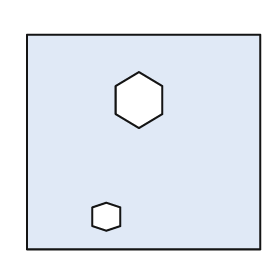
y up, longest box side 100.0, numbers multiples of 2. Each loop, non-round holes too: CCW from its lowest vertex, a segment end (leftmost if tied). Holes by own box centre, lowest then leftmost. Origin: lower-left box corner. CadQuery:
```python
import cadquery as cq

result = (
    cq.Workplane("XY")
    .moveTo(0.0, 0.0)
    .lineTo(100.0, 0.0)
    .lineTo(100.0, 92.0)
    .lineTo(0.0, 92.0)
    .close()
    .moveTo(34.0, 8.0)
    .lineTo(40.0, 10.0)
    .lineTo(40.0, 18.0)
    .lineTo(34.0, 20.0)
    .lineTo(28.0, 18.0)
    .lineTo(28.0, 10.0)
    .close()
    .moveTo(48.0, 52.0)
    .lineTo(58.0, 58.0)
    .lineTo(58.0, 70.0)
    .lineTo(48.0, 76.0)
    .lineTo(38.0, 70.0)
    .lineTo(38.0, 58.0)
    .close()
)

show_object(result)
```